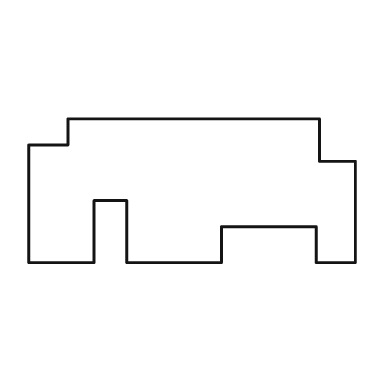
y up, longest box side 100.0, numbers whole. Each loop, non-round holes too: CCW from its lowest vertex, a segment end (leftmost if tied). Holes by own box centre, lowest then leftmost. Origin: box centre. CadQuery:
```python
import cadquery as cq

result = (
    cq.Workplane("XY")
    .moveTo(-50.0, -22.0)
    .lineTo(-30.0, -22.0)
    .lineTo(-30.0, -3.0)
    .lineTo(-20.0, -3.0)
    .lineTo(-20.0, -22.0)
    .lineTo(9.0, -22.0)
    .lineTo(9.0, -11.0)
    .lineTo(38.0, -11.0)
    .lineTo(38.0, -22.0)
    .lineTo(50.0, -22.0)
    .lineTo(50.0, 9.0)
    .lineTo(39.0, 9.0)
    .lineTo(39.0, 22.0)
    .lineTo(-38.0, 22.0)
    .lineTo(-38.0, 14.0)
    .lineTo(-50.0, 14.0)
    .close()
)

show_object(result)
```